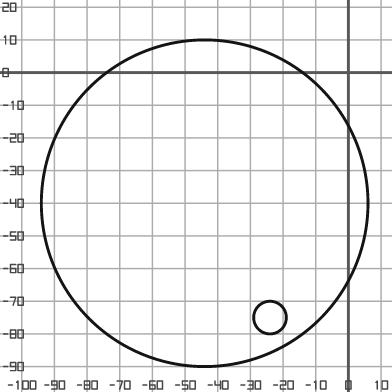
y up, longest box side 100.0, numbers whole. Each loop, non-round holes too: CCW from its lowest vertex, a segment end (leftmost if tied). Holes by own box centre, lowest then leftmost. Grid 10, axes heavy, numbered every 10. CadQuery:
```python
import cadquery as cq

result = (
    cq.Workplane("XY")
    .moveTo(-44.0, -40.0)
    .circle(50.0)
    .moveTo(-24.0, -75.0)
    .circle(5.0)
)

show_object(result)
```